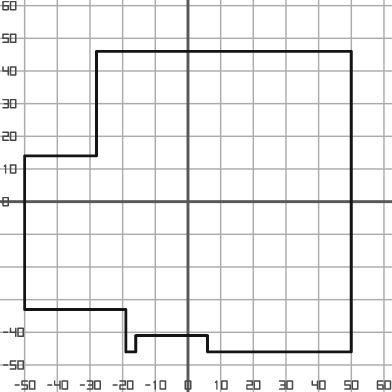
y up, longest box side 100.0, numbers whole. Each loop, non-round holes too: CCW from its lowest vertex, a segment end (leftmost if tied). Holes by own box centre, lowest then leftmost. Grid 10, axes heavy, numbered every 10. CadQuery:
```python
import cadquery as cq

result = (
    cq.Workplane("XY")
    .moveTo(-19.0, -46.0)
    .lineTo(-16.0, -46.0)
    .lineTo(-16.0, -41.0)
    .lineTo(6.0, -41.0)
    .lineTo(6.0, -46.0)
    .lineTo(50.0, -46.0)
    .lineTo(50.0, 46.0)
    .lineTo(-28.0, 46.0)
    .lineTo(-28.0, 14.0)
    .lineTo(-50.0, 14.0)
    .lineTo(-50.0, -33.0)
    .lineTo(-19.0, -33.0)
    .close()
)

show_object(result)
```